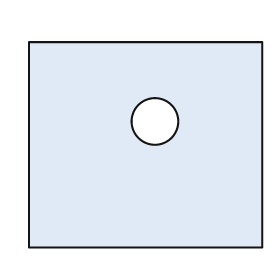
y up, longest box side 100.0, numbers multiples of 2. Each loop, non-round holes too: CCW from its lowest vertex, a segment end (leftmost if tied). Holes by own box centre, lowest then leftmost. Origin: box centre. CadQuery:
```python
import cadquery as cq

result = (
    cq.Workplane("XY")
    .moveTo(-50.0, -44.0)
    .lineTo(50.0, -44.0)
    .lineTo(50.0, 44.0)
    .lineTo(-50.0, 44.0)
    .close()
    .moveTo(4.0, 10.0)
    .circle(10.0)
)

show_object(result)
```